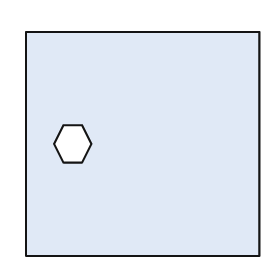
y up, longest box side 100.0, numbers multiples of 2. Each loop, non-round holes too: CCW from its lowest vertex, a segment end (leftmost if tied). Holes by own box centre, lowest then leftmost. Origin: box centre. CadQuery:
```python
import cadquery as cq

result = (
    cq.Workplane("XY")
    .moveTo(-50.0, -48.0)
    .lineTo(50.0, -48.0)
    .lineTo(50.0, 48.0)
    .lineTo(-50.0, 48.0)
    .close()
    .moveTo(-34.0, -8.0)
    .lineTo(-26.0, -8.0)
    .lineTo(-22.0, 0.0)
    .lineTo(-26.0, 8.0)
    .lineTo(-34.0, 8.0)
    .lineTo(-38.0, 0.0)
    .close()
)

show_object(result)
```